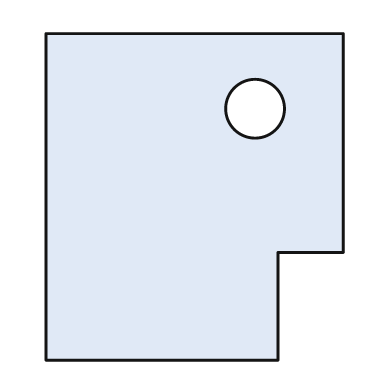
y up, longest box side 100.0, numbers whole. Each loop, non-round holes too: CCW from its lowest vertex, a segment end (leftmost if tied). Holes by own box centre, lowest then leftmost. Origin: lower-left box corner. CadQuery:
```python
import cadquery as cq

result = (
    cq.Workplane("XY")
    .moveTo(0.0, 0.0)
    .lineTo(71.0, 0.0)
    .lineTo(71.0, 33.0)
    .lineTo(91.0, 33.0)
    .lineTo(91.0, 100.0)
    .lineTo(0.0, 100.0)
    .close()
    .moveTo(64.0, 77.0)
    .circle(9.0)
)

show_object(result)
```